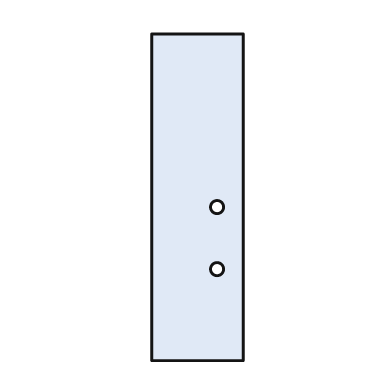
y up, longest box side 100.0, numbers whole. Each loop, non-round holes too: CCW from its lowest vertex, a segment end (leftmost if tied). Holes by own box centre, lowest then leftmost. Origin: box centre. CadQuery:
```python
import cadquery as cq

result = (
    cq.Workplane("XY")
    .moveTo(-14.0, -50.0)
    .lineTo(14.0, -50.0)
    .lineTo(14.0, 50.0)
    .lineTo(-14.0, 50.0)
    .close()
    .moveTo(6.0, -22.0)
    .circle(2.0)
    .moveTo(6.0, -3.0)
    .circle(2.0)
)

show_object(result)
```